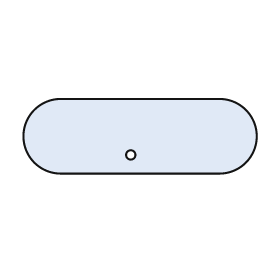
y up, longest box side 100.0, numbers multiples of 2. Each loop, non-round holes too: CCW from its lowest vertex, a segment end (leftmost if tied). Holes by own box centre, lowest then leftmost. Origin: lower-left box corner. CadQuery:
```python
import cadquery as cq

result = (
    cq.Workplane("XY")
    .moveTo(16.0, 0.0)
    .lineTo(84.0, 0.0)
    .threePointArc((100.0, 16.0), (84.0, 32.0))
    .lineTo(16.0, 32.0)
    .threePointArc((0.0, 16.0), (16.0, 0.0))
    .close()
    .moveTo(46.0, 8.0)
    .circle(2.0)
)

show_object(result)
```